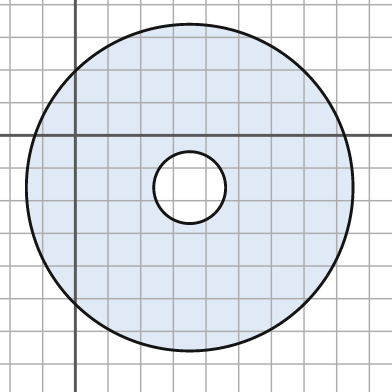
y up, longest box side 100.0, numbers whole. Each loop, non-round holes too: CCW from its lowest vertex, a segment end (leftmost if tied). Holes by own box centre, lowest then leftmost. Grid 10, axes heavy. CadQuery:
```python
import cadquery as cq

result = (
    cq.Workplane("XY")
    .moveTo(35.0, -16.0)
    .circle(50.0)
    .moveTo(35.0, -16.0)
    .circle(11.0)
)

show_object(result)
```